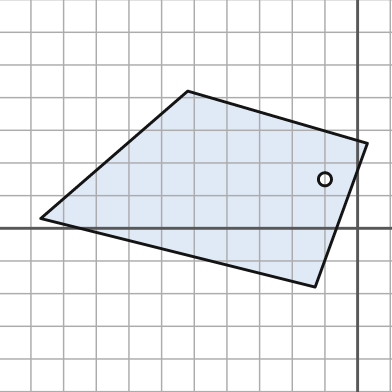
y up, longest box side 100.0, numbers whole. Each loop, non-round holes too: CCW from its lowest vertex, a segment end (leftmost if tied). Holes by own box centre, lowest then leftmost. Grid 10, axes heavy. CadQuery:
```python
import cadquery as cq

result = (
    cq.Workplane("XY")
    .moveTo(-13.0, -18.0)
    .lineTo(3.0, 26.0)
    .lineTo(-52.0, 42.0)
    .lineTo(-97.0, 3.0)
    .close()
    .moveTo(-10.0, 15.0)
    .circle(2.0)
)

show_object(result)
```